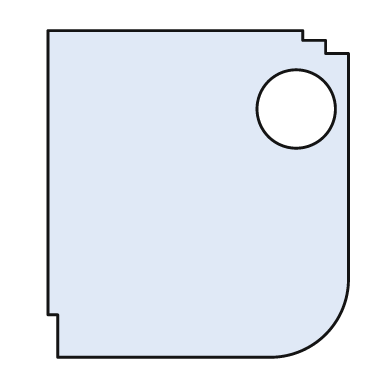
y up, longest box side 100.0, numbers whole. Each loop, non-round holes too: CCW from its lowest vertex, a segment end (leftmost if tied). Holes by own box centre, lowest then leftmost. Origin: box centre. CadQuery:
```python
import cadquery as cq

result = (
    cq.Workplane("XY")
    .moveTo(-43.0, -50.0)
    .lineTo(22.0, -50.0)
    .threePointArc((39.0, -43.0), (46.0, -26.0))
    .lineTo(46.0, 43.0)
    .lineTo(39.0, 43.0)
    .lineTo(39.0, 47.0)
    .lineTo(32.0, 47.0)
    .lineTo(32.0, 50.0)
    .lineTo(-46.0, 50.0)
    .lineTo(-46.0, -37.0)
    .lineTo(-43.0, -37.0)
    .close()
    .moveTo(30.0, 26.0)
    .circle(12.0)
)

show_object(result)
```